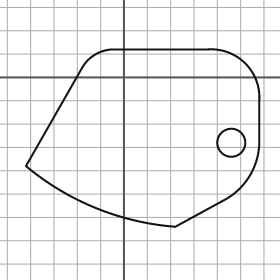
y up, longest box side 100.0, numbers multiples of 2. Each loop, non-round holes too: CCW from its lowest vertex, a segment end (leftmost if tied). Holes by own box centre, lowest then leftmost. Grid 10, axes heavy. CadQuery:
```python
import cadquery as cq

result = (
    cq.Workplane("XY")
    .moveTo(22.0, -64.0)
    .lineTo(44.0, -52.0)
    .threePointArc((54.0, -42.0), (58.0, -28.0))
    .lineTo(58.0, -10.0)
    .threePointArc((52.0, 6.0), (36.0, 12.0))
    .lineTo(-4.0, 12.0)
    .threePointArc((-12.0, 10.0), (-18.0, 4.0))
    .lineTo(-42.0, -38.0)
    .threePointArc((-12.0, -56.0), (22.0, -64.0))
    .close()
    .moveTo(46.0, -28.0)
    .circle(6.0)
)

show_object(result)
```